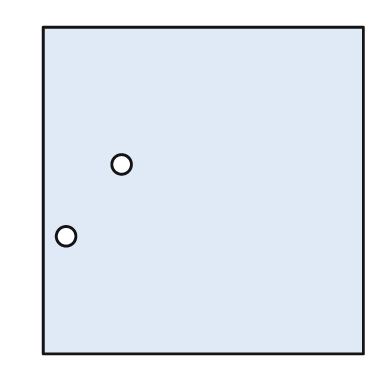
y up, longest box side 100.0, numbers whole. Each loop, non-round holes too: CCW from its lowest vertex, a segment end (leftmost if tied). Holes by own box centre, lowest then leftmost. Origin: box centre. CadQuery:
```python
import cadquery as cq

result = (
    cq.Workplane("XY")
    .moveTo(-49.0, -50.0)
    .lineTo(49.0, -50.0)
    .lineTo(49.0, 50.0)
    .lineTo(-49.0, 50.0)
    .close()
    .moveTo(-42.0, -14.0)
    .circle(3.0)
    .moveTo(-25.0, 8.0)
    .circle(3.0)
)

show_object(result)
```